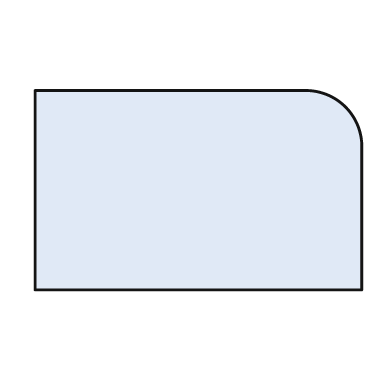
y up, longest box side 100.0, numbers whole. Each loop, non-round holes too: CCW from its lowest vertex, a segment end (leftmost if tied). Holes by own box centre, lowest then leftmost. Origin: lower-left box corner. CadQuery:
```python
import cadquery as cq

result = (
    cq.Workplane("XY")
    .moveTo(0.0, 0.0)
    .lineTo(100.0, 0.0)
    .lineTo(100.0, 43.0)
    .threePointArc((95.0, 56.0), (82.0, 61.0))
    .lineTo(0.0, 61.0)
    .close()
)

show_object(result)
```